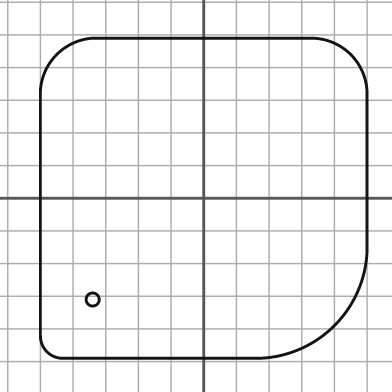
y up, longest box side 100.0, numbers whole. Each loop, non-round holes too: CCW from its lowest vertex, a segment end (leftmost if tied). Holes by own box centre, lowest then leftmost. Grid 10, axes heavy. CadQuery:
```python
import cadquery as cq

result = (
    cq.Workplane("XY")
    .moveTo(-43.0, -49.0)
    .lineTo(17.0, -49.0)
    .threePointArc((40.0, -39.0), (50.0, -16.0))
    .lineTo(50.0, 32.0)
    .threePointArc((45.0, 44.0), (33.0, 49.0))
    .lineTo(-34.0, 49.0)
    .threePointArc((-45.0, 44.0), (-50.0, 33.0))
    .lineTo(-50.0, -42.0)
    .threePointArc((-48.0, -47.0), (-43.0, -49.0))
    .close()
    .moveTo(-34.0, -31.0)
    .circle(2.0)
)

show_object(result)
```